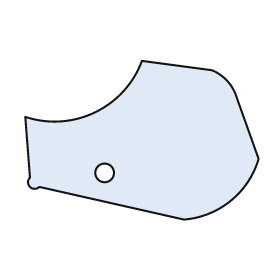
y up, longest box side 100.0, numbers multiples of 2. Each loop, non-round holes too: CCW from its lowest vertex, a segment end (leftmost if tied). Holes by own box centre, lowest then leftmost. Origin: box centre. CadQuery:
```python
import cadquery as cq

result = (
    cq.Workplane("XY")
    .moveTo(18.0, -34.0)
    .threePointArc((38.0, -26.0), (50.0, -8.0))
    .lineTo(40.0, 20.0)
    .threePointArc((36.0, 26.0), (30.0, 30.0))
    .lineTo(0.0, 34.0)
    .threePointArc((-20.0, 12.0), (-50.0, 10.0))
    .lineTo(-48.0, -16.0)
    .threePointArc((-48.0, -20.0), (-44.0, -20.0))
    .close()
    .moveTo(-16.0, -14.0)
    .circle(4.0)
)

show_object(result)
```